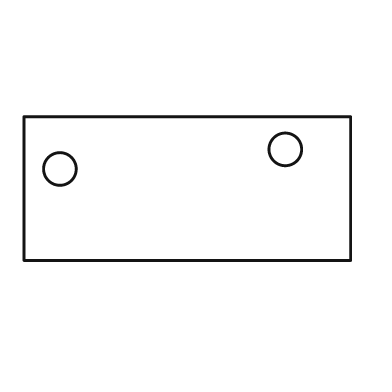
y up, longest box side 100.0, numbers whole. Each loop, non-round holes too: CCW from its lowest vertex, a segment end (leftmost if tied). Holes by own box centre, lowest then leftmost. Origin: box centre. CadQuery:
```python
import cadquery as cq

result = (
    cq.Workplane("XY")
    .moveTo(-50.0, -22.0)
    .lineTo(50.0, -22.0)
    .lineTo(50.0, 22.0)
    .lineTo(-50.0, 22.0)
    .close()
    .moveTo(-39.0, 6.0)
    .circle(5.0)
    .moveTo(30.0, 12.0)
    .circle(5.0)
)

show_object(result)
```